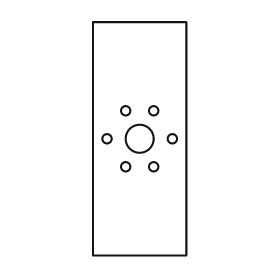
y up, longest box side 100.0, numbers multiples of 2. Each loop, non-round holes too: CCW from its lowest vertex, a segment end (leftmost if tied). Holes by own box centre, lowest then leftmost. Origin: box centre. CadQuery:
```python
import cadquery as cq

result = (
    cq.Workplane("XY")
    .moveTo(-20.0, -50.0)
    .lineTo(20.0, -50.0)
    .lineTo(20.0, 50.0)
    .lineTo(-20.0, 50.0)
    .close()
    .moveTo(-6.0, -12.0)
    .circle(2.0)
    .moveTo(6.0, -12.0)
    .circle(2.0)
    .moveTo(-14.0, 0.0)
    .circle(2.0)
    .moveTo(0.0, 0.0)
    .circle(6.0)
    .moveTo(14.0, 0.0)
    .circle(2.0)
    .moveTo(-6.0, 12.0)
    .circle(2.0)
    .moveTo(6.0, 12.0)
    .circle(2.0)
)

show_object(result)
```